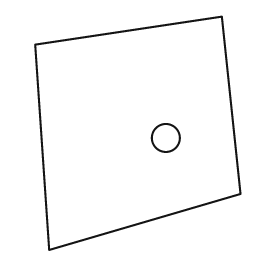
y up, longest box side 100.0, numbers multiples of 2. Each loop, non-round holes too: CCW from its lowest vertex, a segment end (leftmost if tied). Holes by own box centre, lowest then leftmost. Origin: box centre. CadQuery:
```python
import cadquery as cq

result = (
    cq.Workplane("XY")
    .moveTo(-38.0, -50.0)
    .lineTo(44.0, -26.0)
    .lineTo(36.0, 50.0)
    .lineTo(-44.0, 38.0)
    .close()
    .moveTo(12.0, -2.0)
    .circle(6.0)
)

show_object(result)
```